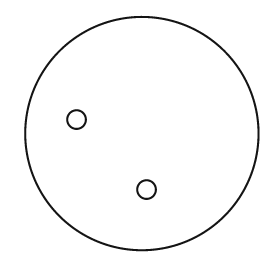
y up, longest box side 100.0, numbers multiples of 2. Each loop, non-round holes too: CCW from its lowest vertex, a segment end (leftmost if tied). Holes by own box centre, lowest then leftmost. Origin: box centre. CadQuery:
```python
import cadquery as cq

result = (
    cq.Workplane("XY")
    .moveTo(0.0, 0.0)
    .circle(50.0)
    .moveTo(2.0, -24.0)
    .circle(4.0)
    .moveTo(-28.0, 6.0)
    .circle(4.0)
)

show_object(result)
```